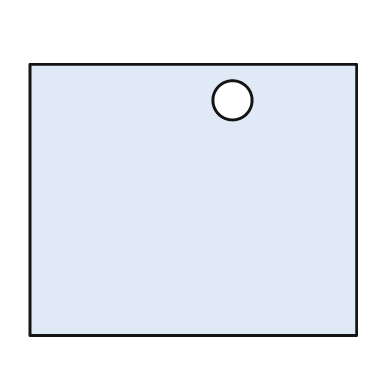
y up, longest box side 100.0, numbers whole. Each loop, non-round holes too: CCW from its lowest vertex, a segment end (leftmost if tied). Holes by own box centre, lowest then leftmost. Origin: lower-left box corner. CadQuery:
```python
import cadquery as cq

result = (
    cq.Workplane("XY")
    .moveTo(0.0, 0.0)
    .lineTo(100.0, 0.0)
    .lineTo(100.0, 83.0)
    .lineTo(0.0, 83.0)
    .close()
    .moveTo(62.0, 72.0)
    .circle(6.0)
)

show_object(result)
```